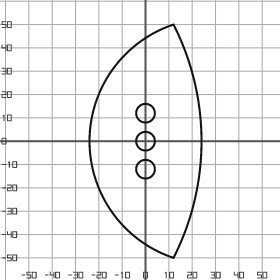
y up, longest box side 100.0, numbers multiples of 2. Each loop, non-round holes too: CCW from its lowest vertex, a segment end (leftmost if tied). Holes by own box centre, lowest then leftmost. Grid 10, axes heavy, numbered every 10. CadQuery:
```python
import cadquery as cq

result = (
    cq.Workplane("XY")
    .moveTo(12.0, -50.0)
    .threePointArc((24.0, 0.0), (12.0, 50.0))
    .threePointArc((-24.0, 0.0), (12.0, -50.0))
    .close()
    .moveTo(0.0, -12.0)
    .circle(4.0)
    .moveTo(0.0, 0.0)
    .circle(4.0)
    .moveTo(0.0, 12.0)
    .circle(4.0)
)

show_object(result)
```